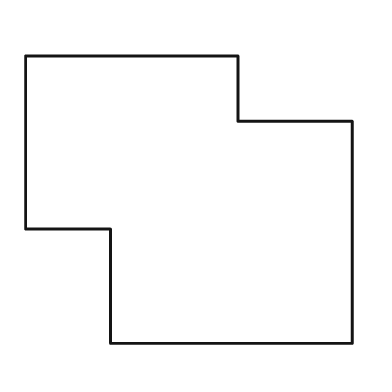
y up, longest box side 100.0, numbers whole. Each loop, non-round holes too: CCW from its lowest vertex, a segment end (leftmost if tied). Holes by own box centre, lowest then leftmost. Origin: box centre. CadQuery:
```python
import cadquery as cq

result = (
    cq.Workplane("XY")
    .moveTo(-24.0, -44.0)
    .lineTo(50.0, -44.0)
    .lineTo(50.0, 24.0)
    .lineTo(15.0, 24.0)
    .lineTo(15.0, 44.0)
    .lineTo(-50.0, 44.0)
    .lineTo(-50.0, -9.0)
    .lineTo(-24.0, -9.0)
    .close()
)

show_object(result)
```